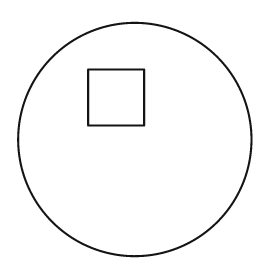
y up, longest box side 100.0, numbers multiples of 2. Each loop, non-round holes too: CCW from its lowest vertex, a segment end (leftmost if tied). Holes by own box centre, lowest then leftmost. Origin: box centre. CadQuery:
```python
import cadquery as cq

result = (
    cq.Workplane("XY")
    .moveTo(0.0, 0.0)
    .circle(50.0)
    .moveTo(-20.0, 6.0)
    .lineTo(4.0, 6.0)
    .lineTo(4.0, 30.0)
    .lineTo(-20.0, 30.0)
    .close()
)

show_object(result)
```